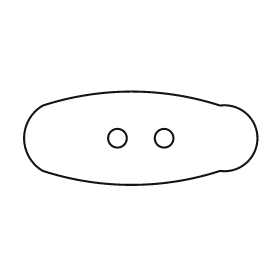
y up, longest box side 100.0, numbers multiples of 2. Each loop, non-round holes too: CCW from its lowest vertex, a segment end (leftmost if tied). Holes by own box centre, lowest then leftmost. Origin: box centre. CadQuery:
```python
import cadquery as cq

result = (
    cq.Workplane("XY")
    .moveTo(-42.0, -14.0)
    .threePointArc((-4.0, -20.0), (34.0, -14.0))
    .threePointArc((50.0, 0.0), (34.0, 14.0))
    .threePointArc((-4.0, 20.0), (-42.0, 14.0))
    .threePointArc((-50.0, 0.0), (-42.0, -14.0))
    .close()
    .moveTo(-10.0, 0.0)
    .circle(4.0)
    .moveTo(10.0, 0.0)
    .circle(4.0)
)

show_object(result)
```